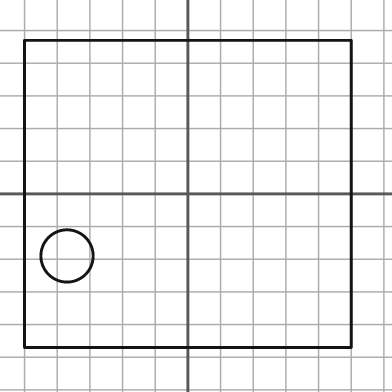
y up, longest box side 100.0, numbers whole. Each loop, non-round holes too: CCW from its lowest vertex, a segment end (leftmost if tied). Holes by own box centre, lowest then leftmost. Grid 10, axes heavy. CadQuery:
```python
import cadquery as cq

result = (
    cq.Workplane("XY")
    .moveTo(-50.0, -47.0)
    .lineTo(50.0, -47.0)
    .lineTo(50.0, 47.0)
    .lineTo(-50.0, 47.0)
    .close()
    .moveTo(-37.0, -19.0)
    .circle(8.0)
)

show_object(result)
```